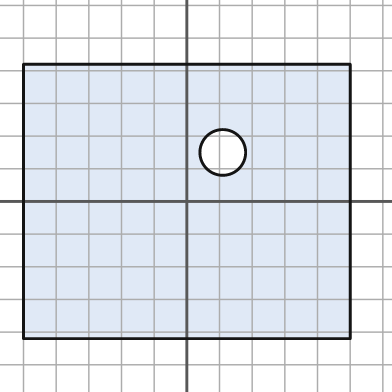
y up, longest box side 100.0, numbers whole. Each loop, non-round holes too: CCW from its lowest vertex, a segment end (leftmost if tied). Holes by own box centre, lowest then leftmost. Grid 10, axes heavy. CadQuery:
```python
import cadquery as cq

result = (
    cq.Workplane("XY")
    .moveTo(-50.0, -42.0)
    .lineTo(50.0, -42.0)
    .lineTo(50.0, 42.0)
    .lineTo(-50.0, 42.0)
    .close()
    .moveTo(11.0, 15.0)
    .circle(7.0)
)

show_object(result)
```